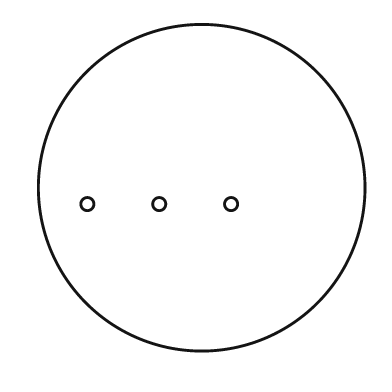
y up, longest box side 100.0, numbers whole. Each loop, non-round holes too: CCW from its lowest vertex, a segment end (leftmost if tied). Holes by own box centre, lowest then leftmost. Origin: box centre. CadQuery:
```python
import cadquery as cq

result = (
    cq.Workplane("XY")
    .moveTo(0.0, 0.0)
    .circle(50.0)
    .moveTo(-35.0, -5.0)
    .circle(2.0)
    .moveTo(-13.0, -5.0)
    .circle(2.0)
    .moveTo(9.0, -5.0)
    .circle(2.0)
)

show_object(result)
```